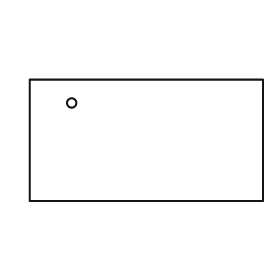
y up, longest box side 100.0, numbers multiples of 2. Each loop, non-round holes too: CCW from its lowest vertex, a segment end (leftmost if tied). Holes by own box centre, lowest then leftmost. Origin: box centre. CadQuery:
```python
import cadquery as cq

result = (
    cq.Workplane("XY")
    .moveTo(-50.0, -26.0)
    .lineTo(50.0, -26.0)
    .lineTo(50.0, 26.0)
    .lineTo(-50.0, 26.0)
    .close()
    .moveTo(-32.0, 16.0)
    .circle(2.0)
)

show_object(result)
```